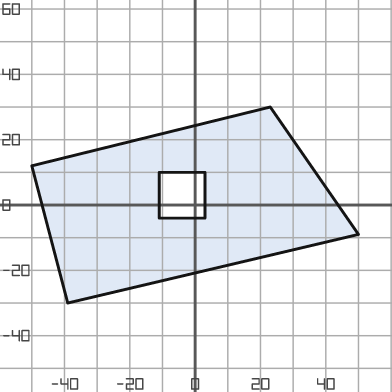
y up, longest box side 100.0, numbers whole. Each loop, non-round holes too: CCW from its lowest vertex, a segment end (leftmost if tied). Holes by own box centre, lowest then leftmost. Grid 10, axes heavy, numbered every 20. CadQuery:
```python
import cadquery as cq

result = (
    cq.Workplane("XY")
    .moveTo(-39.0, -30.0)
    .lineTo(50.0, -9.0)
    .lineTo(23.0, 30.0)
    .lineTo(-50.0, 12.0)
    .close()
    .moveTo(-11.0, -4.0)
    .lineTo(3.0, -4.0)
    .lineTo(3.0, 10.0)
    .lineTo(-11.0, 10.0)
    .close()
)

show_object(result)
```